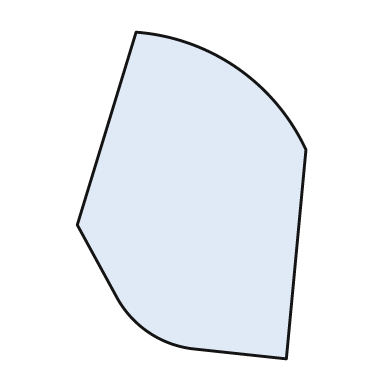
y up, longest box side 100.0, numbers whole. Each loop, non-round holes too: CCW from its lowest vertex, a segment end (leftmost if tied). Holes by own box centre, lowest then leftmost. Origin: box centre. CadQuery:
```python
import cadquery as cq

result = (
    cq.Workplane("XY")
    .moveTo(29.0, -50.0)
    .lineTo(35.0, 14.0)
    .threePointArc((14.0, 39.0), (-17.0, 50.0))
    .lineTo(-35.0, -9.0)
    .lineTo(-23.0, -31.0)
    .threePointArc((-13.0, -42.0), (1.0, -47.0))
    .close()
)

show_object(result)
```